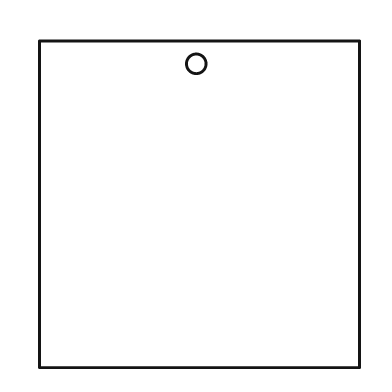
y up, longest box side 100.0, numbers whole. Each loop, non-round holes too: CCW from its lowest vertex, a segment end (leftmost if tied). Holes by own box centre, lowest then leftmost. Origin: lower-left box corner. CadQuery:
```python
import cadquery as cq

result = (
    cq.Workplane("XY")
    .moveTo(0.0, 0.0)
    .lineTo(98.0, 0.0)
    .lineTo(98.0, 100.0)
    .lineTo(0.0, 100.0)
    .close()
    .moveTo(48.0, 93.0)
    .circle(3.0)
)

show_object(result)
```